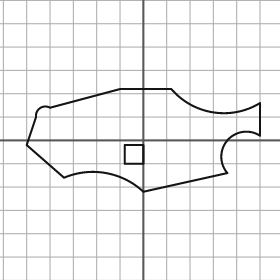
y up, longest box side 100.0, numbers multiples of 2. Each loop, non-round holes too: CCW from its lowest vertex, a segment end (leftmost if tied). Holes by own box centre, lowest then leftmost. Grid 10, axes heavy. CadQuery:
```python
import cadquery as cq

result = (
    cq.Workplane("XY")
    .moveTo(0.0, -22.0)
    .lineTo(36.0, -14.0)
    .threePointArc((36.0, 0.0), (50.0, 2.0))
    .lineTo(50.0, 16.0)
    .threePointArc((30.0, 12.0), (12.0, 22.0))
    .lineTo(-10.0, 22.0)
    .lineTo(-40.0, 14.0)
    .threePointArc((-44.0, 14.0), (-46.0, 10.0))
    .lineTo(-50.0, -2.0)
    .lineTo(-34.0, -16.0)
    .threePointArc((-16.0, -14.0), (0.0, -22.0))
    .close()
    .moveTo(-8.0, -10.0)
    .lineTo(0.0, -10.0)
    .lineTo(0.0, -2.0)
    .lineTo(-8.0, -2.0)
    .close()
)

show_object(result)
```